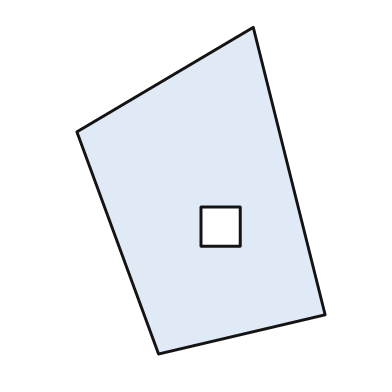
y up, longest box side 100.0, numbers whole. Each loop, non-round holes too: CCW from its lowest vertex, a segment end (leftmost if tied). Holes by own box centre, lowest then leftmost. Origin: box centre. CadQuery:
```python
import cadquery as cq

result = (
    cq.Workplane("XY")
    .moveTo(-13.0, -50.0)
    .lineTo(38.0, -38.0)
    .lineTo(16.0, 50.0)
    .lineTo(-38.0, 18.0)
    .close()
    .moveTo(0.0, -17.0)
    .lineTo(12.0, -17.0)
    .lineTo(12.0, -5.0)
    .lineTo(0.0, -5.0)
    .close()
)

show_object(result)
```